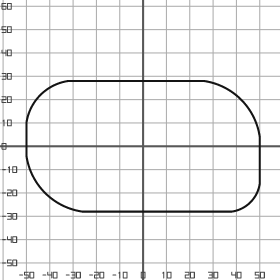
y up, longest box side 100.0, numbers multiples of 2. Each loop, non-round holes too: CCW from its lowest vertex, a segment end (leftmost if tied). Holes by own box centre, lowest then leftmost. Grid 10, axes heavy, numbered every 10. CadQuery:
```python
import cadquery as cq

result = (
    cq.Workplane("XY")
    .moveTo(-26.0, -28.0)
    .lineTo(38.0, -28.0)
    .threePointArc((46.0, -24.0), (50.0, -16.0))
    .lineTo(50.0, 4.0)
    .threePointArc((42.0, 20.0), (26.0, 28.0))
    .lineTo(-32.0, 28.0)
    .threePointArc((-44.0, 22.0), (-50.0, 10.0))
    .lineTo(-50.0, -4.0)
    .threePointArc((-42.0, -20.0), (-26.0, -28.0))
    .close()
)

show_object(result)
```